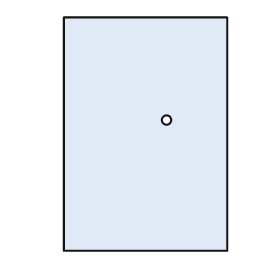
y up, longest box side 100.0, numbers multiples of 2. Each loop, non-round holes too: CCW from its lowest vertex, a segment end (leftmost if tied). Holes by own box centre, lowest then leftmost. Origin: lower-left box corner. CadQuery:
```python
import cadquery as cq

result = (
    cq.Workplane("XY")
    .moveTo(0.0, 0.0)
    .lineTo(70.0, 0.0)
    .lineTo(70.0, 100.0)
    .lineTo(0.0, 100.0)
    .close()
    .moveTo(44.0, 56.0)
    .circle(2.0)
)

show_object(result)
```